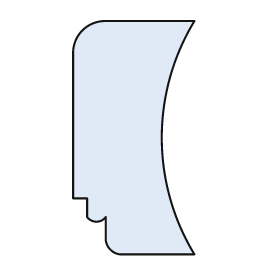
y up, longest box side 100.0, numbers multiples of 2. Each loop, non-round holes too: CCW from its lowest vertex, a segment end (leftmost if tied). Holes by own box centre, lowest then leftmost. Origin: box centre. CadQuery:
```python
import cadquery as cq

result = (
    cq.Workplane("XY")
    .moveTo(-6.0, -50.0)
    .lineTo(26.0, -50.0)
    .threePointArc((12.0, 0.0), (26.0, 50.0))
    .lineTo(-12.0, 50.0)
    .threePointArc((-22.0, 46.0), (-26.0, 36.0))
    .lineTo(-26.0, -26.0)
    .lineTo(-20.0, -26.0)
    .lineTo(-20.0, -34.0)
    .threePointArc((-16.0, -36.0), (-12.0, -34.0))
    .lineTo(-12.0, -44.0)
    .threePointArc((-10.0, -48.0), (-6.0, -50.0))
    .close()
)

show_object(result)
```